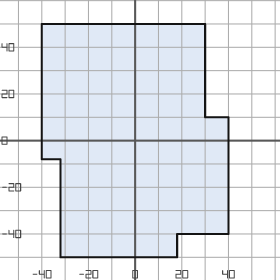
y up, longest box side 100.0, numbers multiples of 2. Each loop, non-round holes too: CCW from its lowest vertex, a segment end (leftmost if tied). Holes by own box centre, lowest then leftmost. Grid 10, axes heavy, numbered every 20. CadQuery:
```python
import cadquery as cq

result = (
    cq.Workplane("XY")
    .moveTo(-32.0, -50.0)
    .lineTo(18.0, -50.0)
    .lineTo(18.0, -40.0)
    .lineTo(40.0, -40.0)
    .lineTo(40.0, 10.0)
    .lineTo(30.0, 10.0)
    .lineTo(30.0, 50.0)
    .lineTo(-40.0, 50.0)
    .lineTo(-40.0, -8.0)
    .lineTo(-32.0, -8.0)
    .close()
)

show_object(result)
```